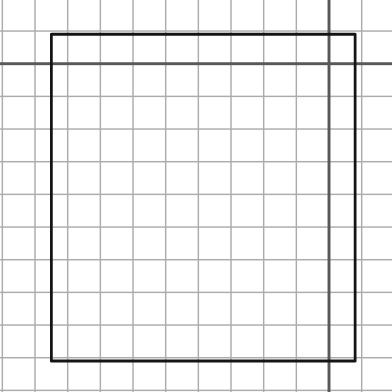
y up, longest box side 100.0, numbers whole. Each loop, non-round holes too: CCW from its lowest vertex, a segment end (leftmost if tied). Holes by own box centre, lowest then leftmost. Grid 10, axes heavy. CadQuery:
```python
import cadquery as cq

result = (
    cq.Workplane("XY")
    .moveTo(-85.0, -91.0)
    .lineTo(8.0, -91.0)
    .lineTo(8.0, 9.0)
    .lineTo(-85.0, 9.0)
    .close()
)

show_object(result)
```